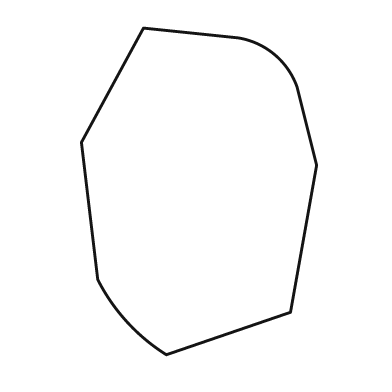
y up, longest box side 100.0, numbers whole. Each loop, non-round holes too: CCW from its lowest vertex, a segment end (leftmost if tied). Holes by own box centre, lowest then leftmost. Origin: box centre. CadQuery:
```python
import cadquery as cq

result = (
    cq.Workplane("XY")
    .moveTo(-10.0, -50.0)
    .lineTo(28.0, -37.0)
    .lineTo(36.0, 8.0)
    .lineTo(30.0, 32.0)
    .threePointArc((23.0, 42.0), (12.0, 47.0))
    .lineTo(-17.0, 50.0)
    .lineTo(-36.0, 15.0)
    .lineTo(-31.0, -27.0)
    .threePointArc((-22.0, -40.0), (-10.0, -50.0))
    .close()
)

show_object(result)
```